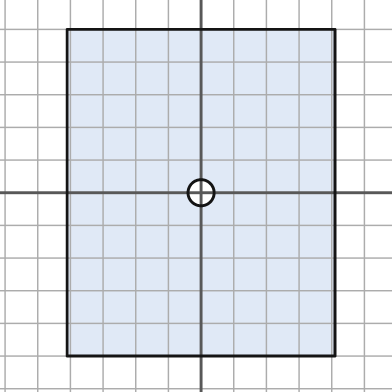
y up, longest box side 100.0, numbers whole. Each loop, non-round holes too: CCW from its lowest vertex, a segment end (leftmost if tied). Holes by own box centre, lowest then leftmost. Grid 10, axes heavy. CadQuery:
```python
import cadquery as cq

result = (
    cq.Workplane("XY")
    .moveTo(-41.0, -50.0)
    .lineTo(41.0, -50.0)
    .lineTo(41.0, 50.0)
    .lineTo(-41.0, 50.0)
    .close()
    .moveTo(0.0, 0.0)
    .circle(4.0)
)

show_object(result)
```